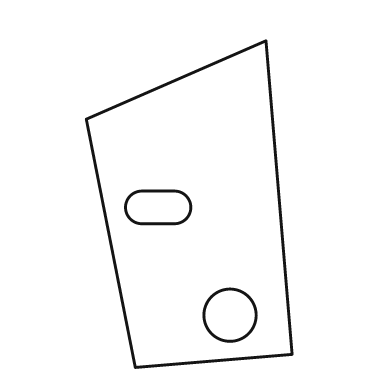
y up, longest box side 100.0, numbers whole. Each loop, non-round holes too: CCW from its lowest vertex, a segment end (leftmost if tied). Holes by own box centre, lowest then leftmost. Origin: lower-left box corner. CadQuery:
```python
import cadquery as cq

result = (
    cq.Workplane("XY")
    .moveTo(15.0, 0.0)
    .lineTo(63.0, 4.0)
    .lineTo(55.0, 100.0)
    .lineTo(0.0, 76.0)
    .close()
    .moveTo(44.0, 16.0)
    .circle(8.0)
    .moveTo(17.0, 44.0)
    .lineTo(27.0, 44.0)
    .threePointArc((32.0, 49.0), (27.0, 54.0))
    .lineTo(17.0, 54.0)
    .threePointArc((12.0, 49.0), (17.0, 44.0))
    .close()
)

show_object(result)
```